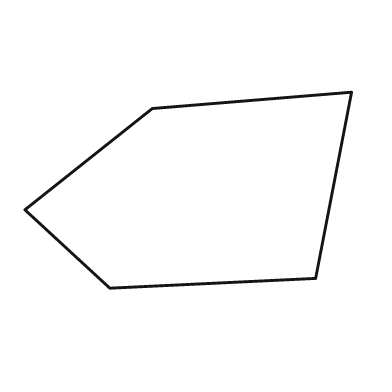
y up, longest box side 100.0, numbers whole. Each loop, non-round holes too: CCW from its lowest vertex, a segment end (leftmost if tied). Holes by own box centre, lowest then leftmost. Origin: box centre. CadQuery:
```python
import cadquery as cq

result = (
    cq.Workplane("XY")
    .moveTo(-24.0, -30.0)
    .lineTo(39.0, -27.0)
    .lineTo(50.0, 30.0)
    .lineTo(-11.0, 25.0)
    .lineTo(-50.0, -6.0)
    .close()
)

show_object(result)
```